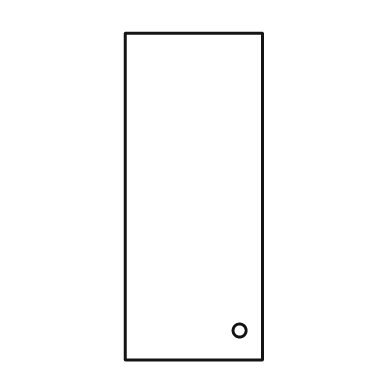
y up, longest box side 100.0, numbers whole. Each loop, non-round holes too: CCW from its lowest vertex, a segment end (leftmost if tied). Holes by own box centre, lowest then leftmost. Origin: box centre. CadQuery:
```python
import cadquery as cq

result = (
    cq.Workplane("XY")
    .moveTo(-21.0, -50.0)
    .lineTo(21.0, -50.0)
    .lineTo(21.0, 50.0)
    .lineTo(-21.0, 50.0)
    .close()
    .moveTo(14.0, -41.0)
    .circle(2.0)
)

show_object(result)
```